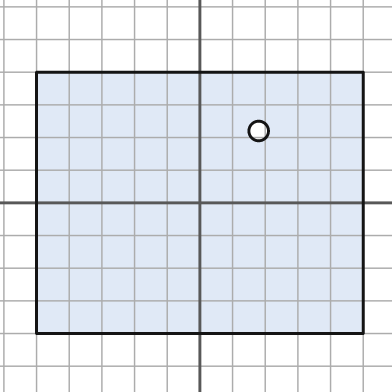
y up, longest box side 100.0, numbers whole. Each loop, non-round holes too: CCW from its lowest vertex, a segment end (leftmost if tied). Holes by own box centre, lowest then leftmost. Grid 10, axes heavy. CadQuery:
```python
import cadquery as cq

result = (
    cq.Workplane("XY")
    .moveTo(-50.0, -40.0)
    .lineTo(50.0, -40.0)
    .lineTo(50.0, 40.0)
    .lineTo(-50.0, 40.0)
    .close()
    .moveTo(18.0, 22.0)
    .circle(3.0)
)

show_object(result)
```